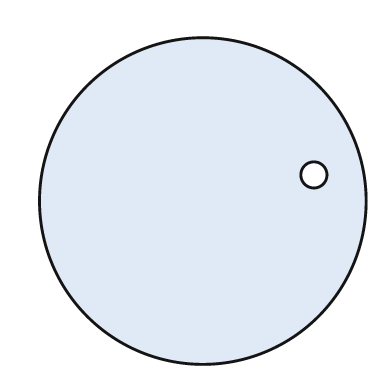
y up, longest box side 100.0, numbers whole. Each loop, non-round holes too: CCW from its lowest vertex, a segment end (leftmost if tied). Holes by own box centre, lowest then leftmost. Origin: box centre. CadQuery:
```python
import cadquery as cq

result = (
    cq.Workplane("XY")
    .moveTo(0.0, 0.0)
    .circle(50.0)
    .moveTo(34.0, 8.0)
    .circle(4.0)
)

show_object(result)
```